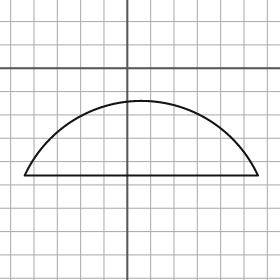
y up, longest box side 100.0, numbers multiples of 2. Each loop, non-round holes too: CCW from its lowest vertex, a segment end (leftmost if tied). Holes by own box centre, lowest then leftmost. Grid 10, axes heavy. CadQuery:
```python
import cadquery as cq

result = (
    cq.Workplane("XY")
    .moveTo(-44.0, -46.0)
    .lineTo(56.0, -46.0)
    .threePointArc((6.0, -14.0), (-44.0, -46.0))
    .close()
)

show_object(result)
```